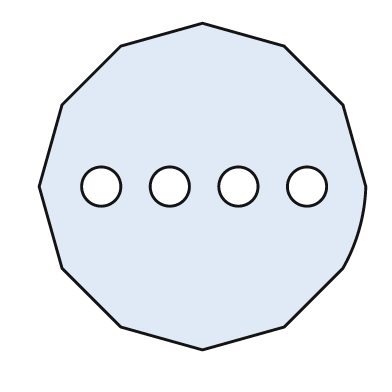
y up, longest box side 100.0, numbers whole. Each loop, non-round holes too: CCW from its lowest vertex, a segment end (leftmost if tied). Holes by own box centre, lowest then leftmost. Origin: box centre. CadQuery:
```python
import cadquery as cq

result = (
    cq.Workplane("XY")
    .moveTo(0.0, -50.0)
    .lineTo(25.0, -43.0)
    .lineTo(43.0, -25.0)
    .threePointArc((48.0, -13.0), (50.0, 0.0))
    .lineTo(43.0, 25.0)
    .lineTo(25.0, 43.0)
    .lineTo(0.0, 50.0)
    .lineTo(-25.0, 43.0)
    .lineTo(-43.0, 25.0)
    .lineTo(-50.0, 0.0)
    .lineTo(-43.0, -25.0)
    .lineTo(-25.0, -43.0)
    .close()
    .moveTo(-31.0, 0.0)
    .circle(6.0)
    .moveTo(-10.0, 0.0)
    .circle(6.0)
    .moveTo(11.0, 0.0)
    .circle(6.0)
    .moveTo(32.0, 0.0)
    .circle(6.0)
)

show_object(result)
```